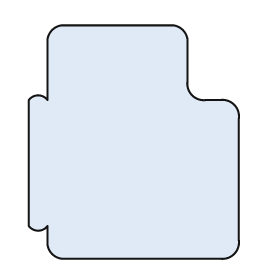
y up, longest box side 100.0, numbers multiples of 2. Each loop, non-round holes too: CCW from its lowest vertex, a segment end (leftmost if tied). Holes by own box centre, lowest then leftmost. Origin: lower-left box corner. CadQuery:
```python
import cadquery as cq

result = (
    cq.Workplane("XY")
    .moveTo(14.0, 0.0)
    .lineTo(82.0, 0.0)
    .threePointArc((88.0, 2.0), (90.0, 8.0))
    .lineTo(90.0, 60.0)
    .threePointArc((88.0, 66.0), (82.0, 68.0))
    .lineTo(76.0, 68.0)
    .threePointArc((70.0, 70.0), (68.0, 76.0))
    .lineTo(68.0, 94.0)
    .threePointArc((66.0, 98.0), (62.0, 100.0))
    .lineTo(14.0, 100.0)
    .threePointArc((10.0, 98.0), (8.0, 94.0))
    .lineTo(8.0, 68.0)
    .threePointArc((4.0, 70.0), (0.0, 68.0))
    .lineTo(0.0, 14.0)
    .threePointArc((4.0, 12.0), (8.0, 14.0))
    .lineTo(8.0, 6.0)
    .threePointArc((10.0, 2.0), (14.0, 0.0))
    .close()
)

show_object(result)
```